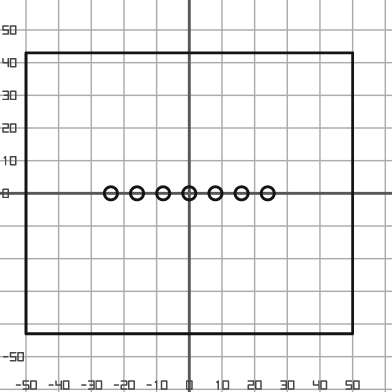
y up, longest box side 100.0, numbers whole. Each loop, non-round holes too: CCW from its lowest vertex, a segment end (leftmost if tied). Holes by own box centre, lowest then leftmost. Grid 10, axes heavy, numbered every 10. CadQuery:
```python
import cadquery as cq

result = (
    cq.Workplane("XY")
    .moveTo(-50.0, -43.0)
    .lineTo(50.0, -43.0)
    .lineTo(50.0, 43.0)
    .lineTo(-50.0, 43.0)
    .close()
    .moveTo(-24.0, 0.0)
    .circle(2.0)
    .moveTo(-16.0, 0.0)
    .circle(2.0)
    .moveTo(-8.0, 0.0)
    .circle(2.0)
    .moveTo(0.0, 0.0)
    .circle(2.0)
    .moveTo(8.0, 0.0)
    .circle(2.0)
    .moveTo(16.0, 0.0)
    .circle(2.0)
    .moveTo(24.0, 0.0)
    .circle(2.0)
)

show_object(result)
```